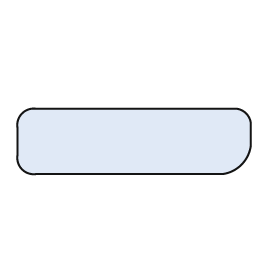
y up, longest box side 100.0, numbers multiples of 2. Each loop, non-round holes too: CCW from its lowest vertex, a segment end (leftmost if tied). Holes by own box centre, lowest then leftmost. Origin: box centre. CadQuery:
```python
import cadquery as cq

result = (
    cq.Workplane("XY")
    .moveTo(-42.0, -14.0)
    .lineTo(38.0, -14.0)
    .threePointArc((46.0, -10.0), (50.0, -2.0))
    .lineTo(50.0, 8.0)
    .threePointArc((48.0, 12.0), (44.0, 14.0))
    .lineTo(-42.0, 14.0)
    .threePointArc((-48.0, 12.0), (-50.0, 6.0))
    .lineTo(-50.0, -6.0)
    .threePointArc((-48.0, -12.0), (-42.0, -14.0))
    .close()
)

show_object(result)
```